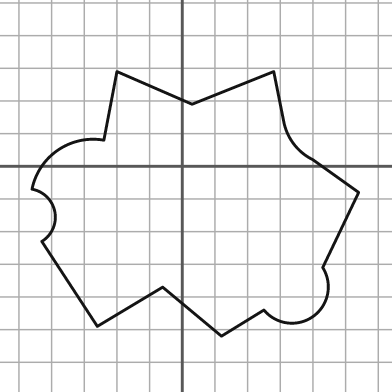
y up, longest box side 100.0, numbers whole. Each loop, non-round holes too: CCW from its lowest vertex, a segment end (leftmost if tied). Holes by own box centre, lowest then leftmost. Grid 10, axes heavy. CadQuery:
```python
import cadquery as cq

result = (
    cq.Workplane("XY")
    .moveTo(12.0, -52.0)
    .lineTo(25.0, -44.0)
    .threePointArc((40.0, -46.0), (43.0, -31.0))
    .lineTo(54.0, -8.0)
    .lineTo(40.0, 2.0)
    .threePointArc((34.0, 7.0), (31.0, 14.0))
    .lineTo(28.0, 29.0)
    .lineTo(3.0, 19.0)
    .lineTo(-20.0, 29.0)
    .lineTo(-24.0, 8.0)
    .threePointArc((-38.0, 5.0), (-46.0, -7.0))
    .threePointArc((-39.0, -14.0), (-43.0, -23.0))
    .lineTo(-26.0, -49.0)
    .lineTo(-6.0, -37.0)
    .close()
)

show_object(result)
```